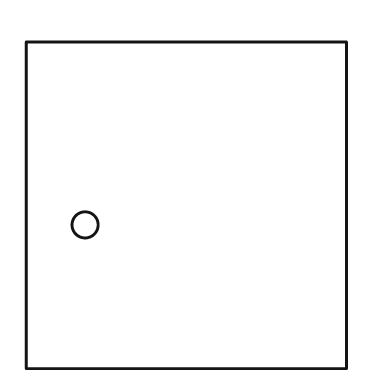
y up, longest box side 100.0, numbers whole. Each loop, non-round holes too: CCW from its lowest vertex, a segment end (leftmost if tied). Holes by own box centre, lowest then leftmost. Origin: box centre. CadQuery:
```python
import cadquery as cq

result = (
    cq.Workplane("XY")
    .moveTo(-49.0, -50.0)
    .lineTo(49.0, -50.0)
    .lineTo(49.0, 50.0)
    .lineTo(-49.0, 50.0)
    .close()
    .moveTo(-31.0, -6.0)
    .circle(4.0)
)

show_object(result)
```